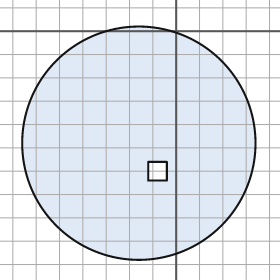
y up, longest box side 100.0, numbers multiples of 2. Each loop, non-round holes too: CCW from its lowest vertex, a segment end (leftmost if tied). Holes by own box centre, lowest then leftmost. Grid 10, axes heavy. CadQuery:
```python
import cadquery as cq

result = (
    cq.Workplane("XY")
    .moveTo(-16.0, -48.0)
    .circle(50.0)
    .moveTo(-12.0, -64.0)
    .lineTo(-4.0, -64.0)
    .lineTo(-4.0, -56.0)
    .lineTo(-12.0, -56.0)
    .close()
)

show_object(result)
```